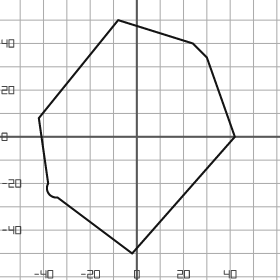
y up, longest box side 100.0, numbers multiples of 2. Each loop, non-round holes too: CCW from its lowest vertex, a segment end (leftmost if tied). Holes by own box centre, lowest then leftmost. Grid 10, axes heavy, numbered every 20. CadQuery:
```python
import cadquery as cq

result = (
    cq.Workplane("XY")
    .moveTo(-2.0, -50.0)
    .lineTo(42.0, 0.0)
    .lineTo(30.0, 34.0)
    .lineTo(24.0, 40.0)
    .lineTo(-8.0, 50.0)
    .lineTo(-42.0, 8.0)
    .lineTo(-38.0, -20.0)
    .threePointArc((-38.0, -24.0), (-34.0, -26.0))
    .close()
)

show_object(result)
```